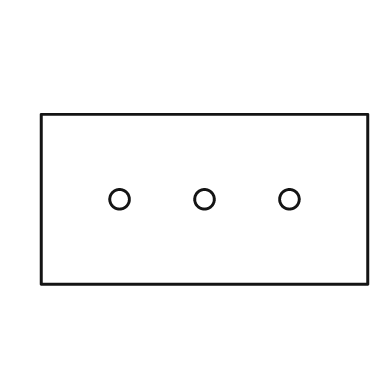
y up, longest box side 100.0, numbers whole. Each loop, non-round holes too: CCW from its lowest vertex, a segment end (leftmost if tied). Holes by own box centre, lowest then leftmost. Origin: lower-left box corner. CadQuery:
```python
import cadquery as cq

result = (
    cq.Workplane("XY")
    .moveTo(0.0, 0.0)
    .lineTo(100.0, 0.0)
    .lineTo(100.0, 52.0)
    .lineTo(0.0, 52.0)
    .close()
    .moveTo(24.0, 26.0)
    .circle(3.0)
    .moveTo(50.0, 26.0)
    .circle(3.0)
    .moveTo(76.0, 26.0)
    .circle(3.0)
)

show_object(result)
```